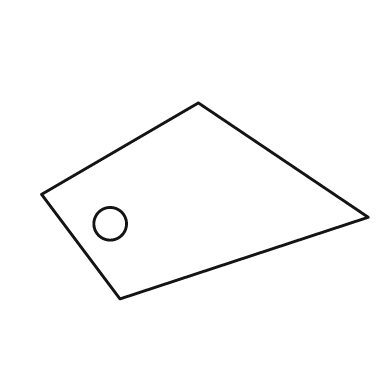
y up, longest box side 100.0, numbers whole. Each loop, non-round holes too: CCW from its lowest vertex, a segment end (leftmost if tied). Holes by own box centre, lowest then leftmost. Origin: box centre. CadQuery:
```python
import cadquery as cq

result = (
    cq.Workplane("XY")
    .moveTo(-26.0, -30.0)
    .lineTo(50.0, -5.0)
    .lineTo(-2.0, 30.0)
    .lineTo(-50.0, 2.0)
    .close()
    .moveTo(-29.0, -7.0)
    .circle(5.0)
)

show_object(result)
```